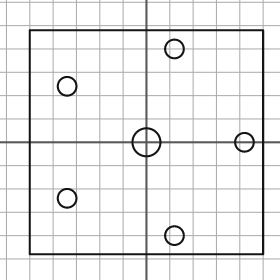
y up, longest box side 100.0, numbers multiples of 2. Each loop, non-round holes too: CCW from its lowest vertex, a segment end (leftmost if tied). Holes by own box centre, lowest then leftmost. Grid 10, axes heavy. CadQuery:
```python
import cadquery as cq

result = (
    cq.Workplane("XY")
    .moveTo(-50.0, -48.0)
    .lineTo(50.0, -48.0)
    .lineTo(50.0, 48.0)
    .lineTo(-50.0, 48.0)
    .close()
    .moveTo(12.0, -40.0)
    .circle(4.0)
    .moveTo(-34.0, -24.0)
    .circle(4.0)
    .moveTo(0.0, 0.0)
    .circle(6.0)
    .moveTo(42.0, 0.0)
    .circle(4.0)
    .moveTo(-34.0, 24.0)
    .circle(4.0)
    .moveTo(12.0, 40.0)
    .circle(4.0)
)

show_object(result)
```